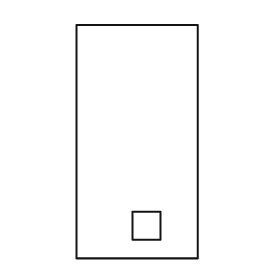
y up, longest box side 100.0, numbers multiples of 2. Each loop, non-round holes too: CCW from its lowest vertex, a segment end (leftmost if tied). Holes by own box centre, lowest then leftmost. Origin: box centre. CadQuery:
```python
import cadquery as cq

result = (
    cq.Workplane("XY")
    .moveTo(-26.0, -50.0)
    .lineTo(26.0, -50.0)
    .lineTo(26.0, 50.0)
    .lineTo(-26.0, 50.0)
    .close()
    .moveTo(-2.0, -42.0)
    .lineTo(10.0, -42.0)
    .lineTo(10.0, -30.0)
    .lineTo(-2.0, -30.0)
    .close()
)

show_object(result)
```